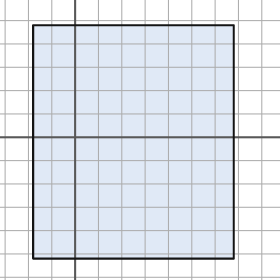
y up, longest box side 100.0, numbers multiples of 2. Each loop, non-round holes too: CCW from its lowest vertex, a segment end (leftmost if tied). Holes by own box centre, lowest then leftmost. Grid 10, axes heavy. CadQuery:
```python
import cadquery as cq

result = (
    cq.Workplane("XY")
    .moveTo(-18.0, -52.0)
    .lineTo(68.0, -52.0)
    .lineTo(68.0, 48.0)
    .lineTo(-18.0, 48.0)
    .close()
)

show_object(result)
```